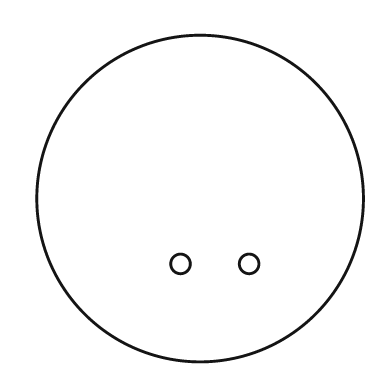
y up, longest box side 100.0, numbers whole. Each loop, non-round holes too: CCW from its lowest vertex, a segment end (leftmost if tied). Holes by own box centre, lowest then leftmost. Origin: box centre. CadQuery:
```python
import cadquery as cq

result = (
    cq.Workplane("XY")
    .moveTo(0.0, 0.0)
    .circle(50.0)
    .moveTo(-6.0, -20.0)
    .circle(3.0)
    .moveTo(15.0, -20.0)
    .circle(3.0)
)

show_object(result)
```